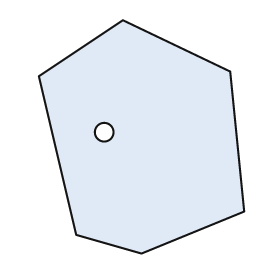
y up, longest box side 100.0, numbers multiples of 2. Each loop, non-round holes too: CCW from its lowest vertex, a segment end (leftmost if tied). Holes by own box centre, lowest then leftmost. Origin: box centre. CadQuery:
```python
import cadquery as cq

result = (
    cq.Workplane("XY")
    .moveTo(0.0, -50.0)
    .lineTo(44.0, -32.0)
    .lineTo(38.0, 28.0)
    .lineTo(-8.0, 50.0)
    .lineTo(-44.0, 26.0)
    .lineTo(-28.0, -42.0)
    .close()
    .moveTo(-16.0, 2.0)
    .circle(4.0)
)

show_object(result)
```